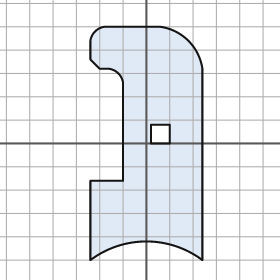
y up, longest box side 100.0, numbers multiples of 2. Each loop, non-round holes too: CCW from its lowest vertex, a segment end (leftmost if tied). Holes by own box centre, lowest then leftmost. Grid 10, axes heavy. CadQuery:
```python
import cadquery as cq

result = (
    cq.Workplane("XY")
    .moveTo(-24.0, -50.0)
    .threePointArc((0.0, -42.0), (24.0, -50.0))
    .lineTo(24.0, 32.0)
    .threePointArc((18.0, 44.0), (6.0, 50.0))
    .lineTo(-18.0, 50.0)
    .threePointArc((-22.0, 48.0), (-24.0, 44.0))
    .lineTo(-24.0, 36.0)
    .lineTo(-20.0, 32.0)
    .lineTo(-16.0, 32.0)
    .threePointArc((-12.0, 30.0), (-10.0, 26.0))
    .lineTo(-10.0, -16.0)
    .lineTo(-24.0, -16.0)
    .close()
    .moveTo(2.0, 0.0)
    .lineTo(10.0, 0.0)
    .lineTo(10.0, 8.0)
    .lineTo(2.0, 8.0)
    .close()
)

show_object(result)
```